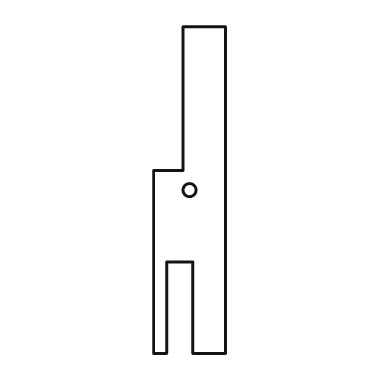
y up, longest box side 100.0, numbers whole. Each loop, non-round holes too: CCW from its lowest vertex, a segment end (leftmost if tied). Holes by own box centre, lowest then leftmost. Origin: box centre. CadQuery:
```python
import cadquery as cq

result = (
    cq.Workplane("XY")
    .moveTo(-11.0, -50.0)
    .lineTo(-7.0, -50.0)
    .lineTo(-7.0, -22.0)
    .lineTo(1.0, -22.0)
    .lineTo(1.0, -50.0)
    .lineTo(11.0, -50.0)
    .lineTo(11.0, 50.0)
    .lineTo(-2.0, 50.0)
    .lineTo(-2.0, 6.0)
    .lineTo(-11.0, 6.0)
    .close()
    .moveTo(0.0, 0.0)
    .circle(2.0)
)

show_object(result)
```